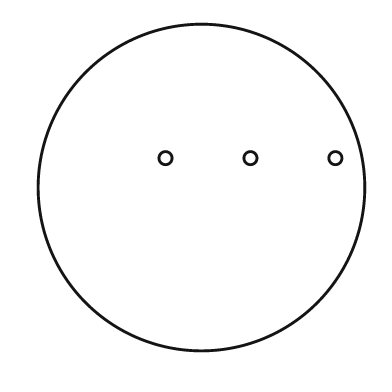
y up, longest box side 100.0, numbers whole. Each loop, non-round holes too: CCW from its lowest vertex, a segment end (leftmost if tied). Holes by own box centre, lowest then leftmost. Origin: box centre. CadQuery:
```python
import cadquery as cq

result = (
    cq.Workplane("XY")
    .moveTo(0.0, 0.0)
    .circle(50.0)
    .moveTo(-11.0, 9.0)
    .circle(2.0)
    .moveTo(15.0, 9.0)
    .circle(2.0)
    .moveTo(41.0, 9.0)
    .circle(2.0)
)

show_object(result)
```